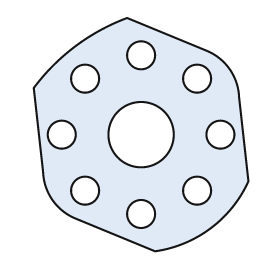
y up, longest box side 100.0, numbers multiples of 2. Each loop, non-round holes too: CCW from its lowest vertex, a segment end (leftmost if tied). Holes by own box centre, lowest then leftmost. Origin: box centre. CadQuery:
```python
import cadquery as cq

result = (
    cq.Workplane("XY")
    .moveTo(6.0, -50.0)
    .threePointArc((30.0, -40.0), (46.0, -20.0))
    .lineTo(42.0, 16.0)
    .threePointArc((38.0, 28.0), (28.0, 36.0))
    .lineTo(-6.0, 50.0)
    .threePointArc((-28.0, 38.0), (-46.0, 20.0))
    .lineTo(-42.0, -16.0)
    .threePointArc((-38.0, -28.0), (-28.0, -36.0))
    .close()
    .moveTo(0.0, -34.0)
    .circle(6.0)
    .moveTo(-24.0, -24.0)
    .circle(6.0)
    .moveTo(24.0, -24.0)
    .circle(6.0)
    .moveTo(-34.0, 0.0)
    .circle(6.0)
    .moveTo(0.0, 0.0)
    .circle(14.0)
    .moveTo(34.0, 0.0)
    .circle(6.0)
    .moveTo(-24.0, 24.0)
    .circle(6.0)
    .moveTo(24.0, 24.0)
    .circle(6.0)
    .moveTo(0.0, 34.0)
    .circle(6.0)
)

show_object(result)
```